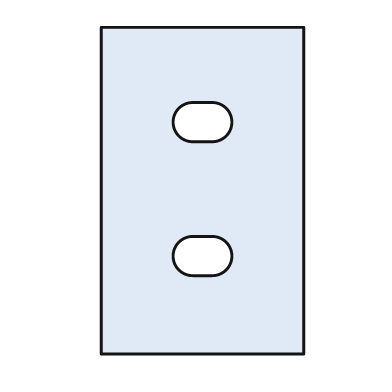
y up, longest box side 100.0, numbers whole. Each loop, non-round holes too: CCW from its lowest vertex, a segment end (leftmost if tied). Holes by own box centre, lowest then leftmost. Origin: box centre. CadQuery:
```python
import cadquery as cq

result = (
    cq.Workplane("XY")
    .moveTo(-31.0, -50.0)
    .lineTo(31.0, -50.0)
    .lineTo(31.0, 50.0)
    .lineTo(-31.0, 50.0)
    .close()
    .moveTo(-3.0, -26.0)
    .lineTo(3.0, -26.0)
    .threePointArc((9.0, -20.0), (3.0, -14.0))
    .lineTo(-3.0, -14.0)
    .threePointArc((-9.0, -20.0), (-3.0, -26.0))
    .close()
    .moveTo(-3.0, 15.0)
    .lineTo(3.0, 15.0)
    .threePointArc((9.0, 21.0), (3.0, 27.0))
    .lineTo(-3.0, 27.0)
    .threePointArc((-9.0, 21.0), (-3.0, 15.0))
    .close()
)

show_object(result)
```